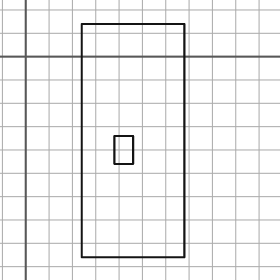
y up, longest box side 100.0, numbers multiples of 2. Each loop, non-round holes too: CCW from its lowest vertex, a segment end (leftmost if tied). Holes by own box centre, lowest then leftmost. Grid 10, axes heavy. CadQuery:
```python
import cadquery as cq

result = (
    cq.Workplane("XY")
    .moveTo(24.0, -86.0)
    .lineTo(68.0, -86.0)
    .lineTo(68.0, 14.0)
    .lineTo(24.0, 14.0)
    .close()
    .moveTo(38.0, -46.0)
    .lineTo(46.0, -46.0)
    .lineTo(46.0, -34.0)
    .lineTo(38.0, -34.0)
    .close()
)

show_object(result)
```